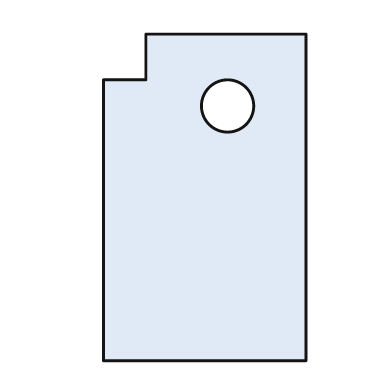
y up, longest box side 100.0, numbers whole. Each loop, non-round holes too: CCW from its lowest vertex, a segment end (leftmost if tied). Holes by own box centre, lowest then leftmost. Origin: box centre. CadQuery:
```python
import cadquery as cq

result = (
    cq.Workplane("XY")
    .moveTo(-31.0, -50.0)
    .lineTo(31.0, -50.0)
    .lineTo(31.0, 50.0)
    .lineTo(-18.0, 50.0)
    .lineTo(-18.0, 36.0)
    .lineTo(-31.0, 36.0)
    .close()
    .moveTo(7.0, 28.0)
    .circle(8.0)
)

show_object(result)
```